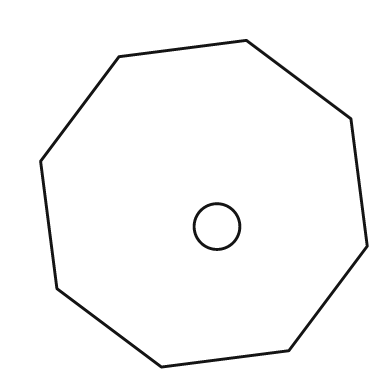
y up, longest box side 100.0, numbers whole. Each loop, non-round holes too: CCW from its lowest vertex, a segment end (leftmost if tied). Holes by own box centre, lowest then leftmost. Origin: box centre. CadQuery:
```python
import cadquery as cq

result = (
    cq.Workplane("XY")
    .moveTo(-13.0, -50.0)
    .lineTo(26.0, -45.0)
    .lineTo(50.0, -13.0)
    .lineTo(45.0, 26.0)
    .lineTo(13.0, 50.0)
    .lineTo(-26.0, 45.0)
    .lineTo(-50.0, 13.0)
    .lineTo(-45.0, -26.0)
    .close()
    .moveTo(4.0, -7.0)
    .circle(7.0)
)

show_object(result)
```